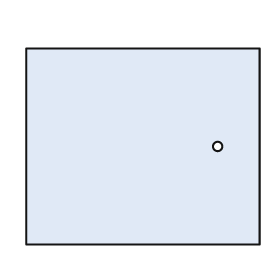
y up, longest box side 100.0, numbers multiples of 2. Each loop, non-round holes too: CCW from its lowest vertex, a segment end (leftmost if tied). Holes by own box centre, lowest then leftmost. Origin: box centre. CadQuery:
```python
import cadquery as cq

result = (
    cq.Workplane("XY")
    .moveTo(-50.0, -42.0)
    .lineTo(50.0, -42.0)
    .lineTo(50.0, 42.0)
    .lineTo(-50.0, 42.0)
    .close()
    .moveTo(32.0, 0.0)
    .circle(2.0)
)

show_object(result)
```